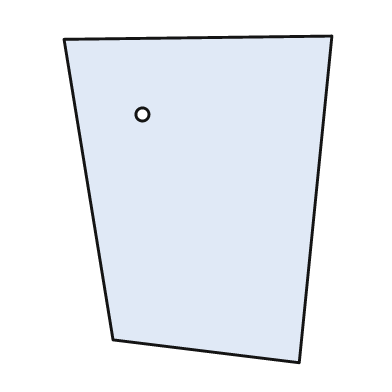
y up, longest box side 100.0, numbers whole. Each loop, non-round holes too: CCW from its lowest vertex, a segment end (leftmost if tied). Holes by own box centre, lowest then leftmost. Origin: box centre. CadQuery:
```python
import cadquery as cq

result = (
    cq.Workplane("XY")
    .moveTo(31.0, -50.0)
    .lineTo(41.0, 50.0)
    .lineTo(-41.0, 49.0)
    .lineTo(-26.0, -43.0)
    .close()
    .moveTo(-17.0, 26.0)
    .circle(2.0)
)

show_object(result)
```